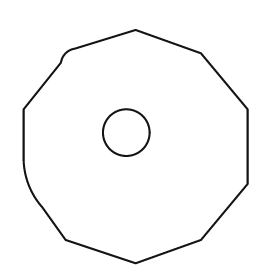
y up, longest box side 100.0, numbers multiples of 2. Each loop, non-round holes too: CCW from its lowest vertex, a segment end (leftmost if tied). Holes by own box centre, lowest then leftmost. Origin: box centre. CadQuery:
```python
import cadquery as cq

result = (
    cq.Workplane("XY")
    .moveTo(0.0, -50.0)
    .lineTo(28.0, -40.0)
    .lineTo(48.0, -16.0)
    .lineTo(48.0, 16.0)
    .lineTo(28.0, 40.0)
    .lineTo(0.0, 50.0)
    .lineTo(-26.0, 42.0)
    .threePointArc((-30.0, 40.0), (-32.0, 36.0))
    .lineTo(-48.0, 16.0)
    .lineTo(-48.0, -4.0)
    .threePointArc((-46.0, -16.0), (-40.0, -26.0))
    .lineTo(-30.0, -40.0)
    .close()
    .moveTo(-4.0, 6.0)
    .circle(10.0)
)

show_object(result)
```